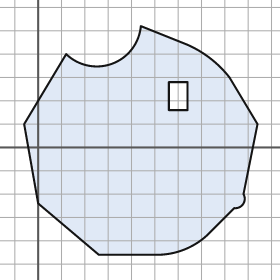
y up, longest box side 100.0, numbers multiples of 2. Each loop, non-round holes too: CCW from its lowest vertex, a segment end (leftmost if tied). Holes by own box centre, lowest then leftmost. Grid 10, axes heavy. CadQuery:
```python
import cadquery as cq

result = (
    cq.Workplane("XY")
    .moveTo(26.0, -46.0)
    .lineTo(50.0, -46.0)
    .threePointArc((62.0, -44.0), (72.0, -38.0))
    .lineTo(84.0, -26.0)
    .threePointArc((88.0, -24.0), (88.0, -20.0))
    .lineTo(94.0, 10.0)
    .lineTo(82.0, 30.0)
    .threePointArc((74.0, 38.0), (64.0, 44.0))
    .lineTo(44.0, 52.0)
    .threePointArc((32.0, 36.0), (12.0, 40.0))
    .lineTo(-6.0, 10.0)
    .lineTo(0.0, -24.0)
    .close()
    .moveTo(56.0, 16.0)
    .lineTo(64.0, 16.0)
    .lineTo(64.0, 28.0)
    .lineTo(56.0, 28.0)
    .close()
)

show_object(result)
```